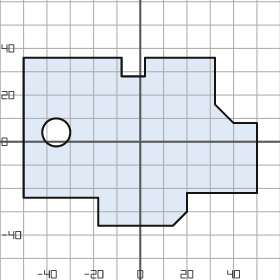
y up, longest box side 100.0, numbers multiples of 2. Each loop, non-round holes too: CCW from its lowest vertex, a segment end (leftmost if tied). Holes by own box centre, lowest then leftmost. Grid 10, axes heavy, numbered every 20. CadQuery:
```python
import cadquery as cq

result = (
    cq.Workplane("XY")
    .moveTo(-18.0, -36.0)
    .lineTo(14.0, -36.0)
    .lineTo(20.0, -30.0)
    .lineTo(20.0, -22.0)
    .lineTo(50.0, -22.0)
    .lineTo(50.0, 8.0)
    .lineTo(40.0, 8.0)
    .lineTo(32.0, 16.0)
    .lineTo(32.0, 36.0)
    .lineTo(2.0, 36.0)
    .lineTo(2.0, 28.0)
    .lineTo(-8.0, 28.0)
    .lineTo(-8.0, 36.0)
    .lineTo(-50.0, 36.0)
    .lineTo(-50.0, -24.0)
    .lineTo(-18.0, -24.0)
    .close()
    .moveTo(-36.0, 4.0)
    .circle(6.0)
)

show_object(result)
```